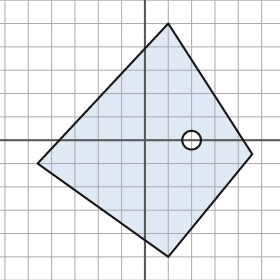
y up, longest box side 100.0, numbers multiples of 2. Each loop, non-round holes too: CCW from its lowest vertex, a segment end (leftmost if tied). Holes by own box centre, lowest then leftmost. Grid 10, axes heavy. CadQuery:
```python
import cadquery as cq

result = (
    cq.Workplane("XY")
    .moveTo(10.0, -50.0)
    .lineTo(46.0, -6.0)
    .lineTo(10.0, 50.0)
    .lineTo(-46.0, -10.0)
    .close()
    .moveTo(20.0, 0.0)
    .circle(4.0)
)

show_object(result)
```